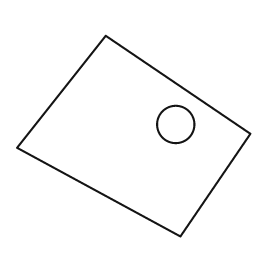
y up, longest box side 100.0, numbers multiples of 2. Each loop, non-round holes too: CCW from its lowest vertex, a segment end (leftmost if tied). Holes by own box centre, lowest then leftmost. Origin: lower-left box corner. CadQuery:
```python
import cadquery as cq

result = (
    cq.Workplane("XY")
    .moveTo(70.0, 0.0)
    .lineTo(100.0, 44.0)
    .lineTo(38.0, 86.0)
    .lineTo(0.0, 38.0)
    .close()
    .moveTo(68.0, 48.0)
    .circle(8.0)
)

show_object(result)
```